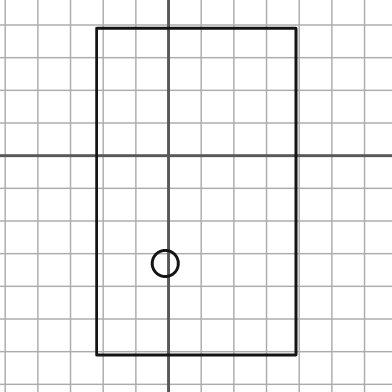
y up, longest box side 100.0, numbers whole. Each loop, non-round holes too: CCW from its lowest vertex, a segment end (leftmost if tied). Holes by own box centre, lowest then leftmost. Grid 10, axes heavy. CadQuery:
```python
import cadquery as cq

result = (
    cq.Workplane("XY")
    .moveTo(-22.0, -61.0)
    .lineTo(39.0, -61.0)
    .lineTo(39.0, 39.0)
    .lineTo(-22.0, 39.0)
    .close()
    .moveTo(-1.0, -33.0)
    .circle(4.0)
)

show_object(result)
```